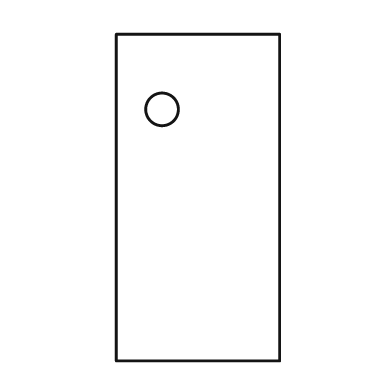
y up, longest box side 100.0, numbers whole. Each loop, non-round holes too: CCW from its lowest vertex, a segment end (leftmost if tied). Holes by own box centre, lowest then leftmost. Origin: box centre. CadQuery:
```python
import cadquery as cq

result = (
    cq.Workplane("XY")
    .moveTo(-25.0, -50.0)
    .lineTo(25.0, -50.0)
    .lineTo(25.0, 50.0)
    .lineTo(-25.0, 50.0)
    .close()
    .moveTo(-11.0, 27.0)
    .circle(5.0)
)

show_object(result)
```